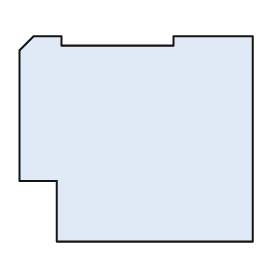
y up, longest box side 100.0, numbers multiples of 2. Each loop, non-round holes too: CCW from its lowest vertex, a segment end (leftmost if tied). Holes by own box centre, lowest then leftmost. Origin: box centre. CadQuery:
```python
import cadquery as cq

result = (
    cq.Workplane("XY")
    .moveTo(-34.0, -44.0)
    .lineTo(50.0, -44.0)
    .lineTo(50.0, 44.0)
    .lineTo(16.0, 44.0)
    .lineTo(16.0, 40.0)
    .lineTo(-32.0, 40.0)
    .lineTo(-32.0, 44.0)
    .lineTo(-44.0, 44.0)
    .lineTo(-50.0, 38.0)
    .lineTo(-50.0, -18.0)
    .lineTo(-34.0, -18.0)
    .close()
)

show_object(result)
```